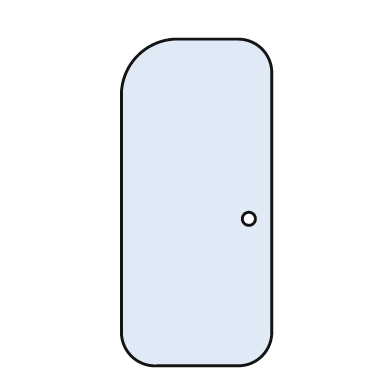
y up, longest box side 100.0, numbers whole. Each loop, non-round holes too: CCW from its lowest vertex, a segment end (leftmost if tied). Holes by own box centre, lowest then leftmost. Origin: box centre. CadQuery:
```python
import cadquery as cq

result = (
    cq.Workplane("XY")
    .moveTo(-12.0, -50.0)
    .lineTo(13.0, -50.0)
    .threePointArc((20.0, -47.0), (23.0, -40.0))
    .lineTo(23.0, 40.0)
    .threePointArc((20.0, 47.0), (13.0, 50.0))
    .lineTo(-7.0, 50.0)
    .threePointArc((-18.0, 45.0), (-23.0, 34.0))
    .lineTo(-23.0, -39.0)
    .threePointArc((-20.0, -47.0), (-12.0, -50.0))
    .close()
    .moveTo(16.0, -5.0)
    .circle(2.0)
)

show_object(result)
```